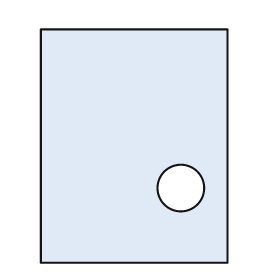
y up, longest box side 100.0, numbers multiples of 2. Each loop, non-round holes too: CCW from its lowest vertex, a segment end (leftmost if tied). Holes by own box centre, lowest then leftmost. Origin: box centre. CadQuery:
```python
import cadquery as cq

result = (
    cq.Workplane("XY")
    .moveTo(-40.0, -50.0)
    .lineTo(40.0, -50.0)
    .lineTo(40.0, 50.0)
    .lineTo(-40.0, 50.0)
    .close()
    .moveTo(20.0, -18.0)
    .circle(10.0)
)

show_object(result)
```